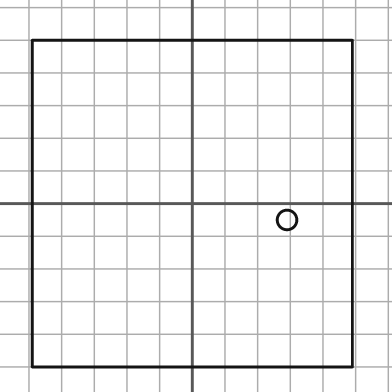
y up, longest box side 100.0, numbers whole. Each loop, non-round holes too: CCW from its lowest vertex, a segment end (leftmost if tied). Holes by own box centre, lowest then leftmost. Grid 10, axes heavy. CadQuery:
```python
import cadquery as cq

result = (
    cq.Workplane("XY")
    .moveTo(-49.0, -50.0)
    .lineTo(49.0, -50.0)
    .lineTo(49.0, 50.0)
    .lineTo(-49.0, 50.0)
    .close()
    .moveTo(29.0, -5.0)
    .circle(3.0)
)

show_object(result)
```